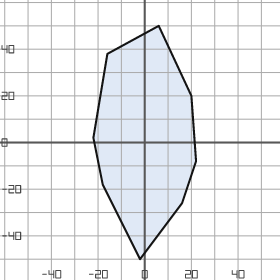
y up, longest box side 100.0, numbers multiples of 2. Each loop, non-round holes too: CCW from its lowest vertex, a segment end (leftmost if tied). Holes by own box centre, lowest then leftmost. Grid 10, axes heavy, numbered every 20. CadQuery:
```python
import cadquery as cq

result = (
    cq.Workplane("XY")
    .moveTo(-2.0, -50.0)
    .lineTo(16.0, -26.0)
    .lineTo(22.0, -8.0)
    .lineTo(20.0, 20.0)
    .lineTo(6.0, 50.0)
    .lineTo(-16.0, 38.0)
    .lineTo(-22.0, 2.0)
    .lineTo(-18.0, -18.0)
    .close()
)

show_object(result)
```